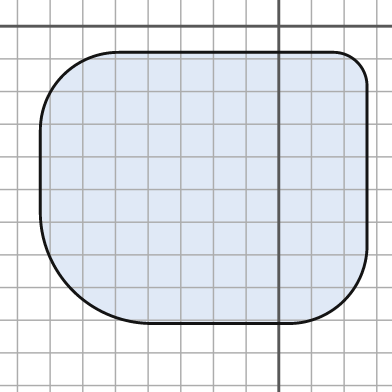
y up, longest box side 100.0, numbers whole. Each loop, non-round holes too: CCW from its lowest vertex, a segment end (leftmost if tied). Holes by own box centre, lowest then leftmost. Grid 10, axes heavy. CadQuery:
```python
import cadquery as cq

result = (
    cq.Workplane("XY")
    .moveTo(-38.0, -91.0)
    .lineTo(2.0, -91.0)
    .threePointArc((20.0, -84.0), (27.0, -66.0))
    .lineTo(27.0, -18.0)
    .threePointArc((24.0, -11.0), (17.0, -8.0))
    .lineTo(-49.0, -8.0)
    .threePointArc((-66.0, -15.0), (-73.0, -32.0))
    .lineTo(-73.0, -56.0)
    .threePointArc((-63.0, -81.0), (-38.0, -91.0))
    .close()
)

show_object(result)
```